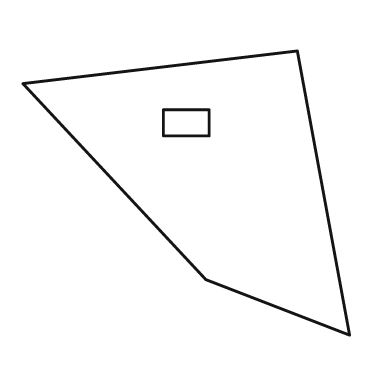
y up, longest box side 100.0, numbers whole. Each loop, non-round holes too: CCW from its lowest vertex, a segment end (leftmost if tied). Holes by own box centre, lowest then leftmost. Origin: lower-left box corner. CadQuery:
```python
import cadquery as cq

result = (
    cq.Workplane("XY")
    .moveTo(100.0, 0.0)
    .lineTo(84.0, 87.0)
    .lineTo(0.0, 77.0)
    .lineTo(56.0, 17.0)
    .close()
    .moveTo(43.0, 61.0)
    .lineTo(57.0, 61.0)
    .lineTo(57.0, 69.0)
    .lineTo(43.0, 69.0)
    .close()
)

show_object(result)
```